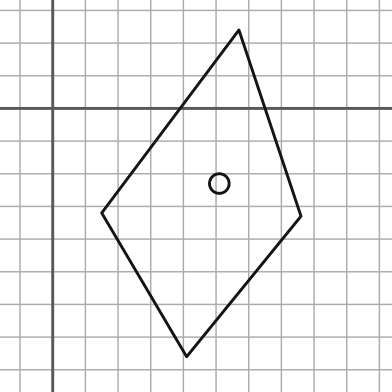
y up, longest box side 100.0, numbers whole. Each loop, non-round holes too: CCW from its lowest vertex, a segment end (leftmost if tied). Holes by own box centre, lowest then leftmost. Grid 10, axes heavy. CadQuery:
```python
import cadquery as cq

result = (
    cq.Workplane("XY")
    .moveTo(41.0, -76.0)
    .lineTo(76.0, -33.0)
    .lineTo(57.0, 24.0)
    .lineTo(15.0, -32.0)
    .close()
    .moveTo(51.0, -23.0)
    .circle(3.0)
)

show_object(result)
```